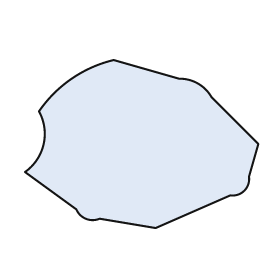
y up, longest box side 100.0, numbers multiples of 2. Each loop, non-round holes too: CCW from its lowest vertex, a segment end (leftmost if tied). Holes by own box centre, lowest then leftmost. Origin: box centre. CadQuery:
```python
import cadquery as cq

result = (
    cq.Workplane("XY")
    .moveTo(6.0, -36.0)
    .lineTo(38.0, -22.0)
    .threePointArc((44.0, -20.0), (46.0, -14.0))
    .lineTo(50.0, 0.0)
    .lineTo(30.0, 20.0)
    .threePointArc((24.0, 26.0), (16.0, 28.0))
    .lineTo(-12.0, 36.0)
    .threePointArc((-30.0, 28.0), (-44.0, 14.0))
    .threePointArc((-42.0, 0.0), (-50.0, -12.0))
    .lineTo(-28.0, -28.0)
    .threePointArc((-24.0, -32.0), (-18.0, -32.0))
    .close()
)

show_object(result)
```